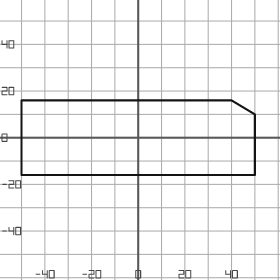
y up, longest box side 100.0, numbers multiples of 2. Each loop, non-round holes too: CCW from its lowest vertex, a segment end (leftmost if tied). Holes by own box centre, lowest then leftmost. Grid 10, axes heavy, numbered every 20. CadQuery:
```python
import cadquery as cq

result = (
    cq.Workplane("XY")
    .moveTo(-50.0, -16.0)
    .lineTo(50.0, -16.0)
    .lineTo(50.0, 10.0)
    .lineTo(40.0, 16.0)
    .lineTo(-50.0, 16.0)
    .close()
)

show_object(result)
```